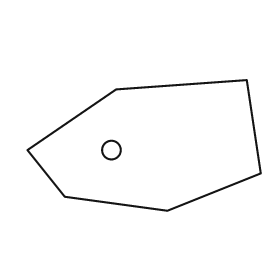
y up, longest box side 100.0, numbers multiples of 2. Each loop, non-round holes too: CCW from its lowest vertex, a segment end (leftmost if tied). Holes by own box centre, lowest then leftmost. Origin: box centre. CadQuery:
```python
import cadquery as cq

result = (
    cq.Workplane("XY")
    .moveTo(10.0, -28.0)
    .lineTo(50.0, -12.0)
    .lineTo(44.0, 28.0)
    .lineTo(-12.0, 24.0)
    .lineTo(-50.0, -2.0)
    .lineTo(-34.0, -22.0)
    .close()
    .moveTo(-14.0, -2.0)
    .circle(4.0)
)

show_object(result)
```